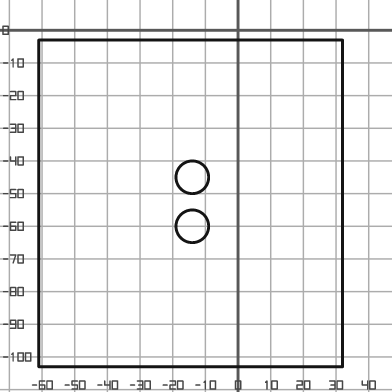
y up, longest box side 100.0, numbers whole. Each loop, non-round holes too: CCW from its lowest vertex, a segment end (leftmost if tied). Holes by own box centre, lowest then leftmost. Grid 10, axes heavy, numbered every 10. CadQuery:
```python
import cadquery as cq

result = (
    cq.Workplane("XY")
    .moveTo(-61.0, -103.0)
    .lineTo(32.0, -103.0)
    .lineTo(32.0, -3.0)
    .lineTo(-61.0, -3.0)
    .close()
    .moveTo(-14.0, -60.0)
    .circle(5.0)
    .moveTo(-14.0, -45.0)
    .circle(5.0)
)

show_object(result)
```